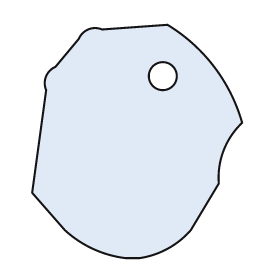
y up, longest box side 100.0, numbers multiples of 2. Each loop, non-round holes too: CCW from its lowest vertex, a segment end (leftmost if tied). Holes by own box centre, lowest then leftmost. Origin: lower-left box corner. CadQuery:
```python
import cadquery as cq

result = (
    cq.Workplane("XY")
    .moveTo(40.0, 0.0)
    .lineTo(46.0, 0.0)
    .threePointArc((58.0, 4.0), (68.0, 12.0))
    .lineTo(80.0, 32.0)
    .threePointArc((82.0, 46.0), (90.0, 58.0))
    .threePointArc((78.0, 82.0), (58.0, 100.0))
    .lineTo(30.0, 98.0)
    .threePointArc((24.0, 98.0), (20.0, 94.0))
    .lineTo(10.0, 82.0)
    .threePointArc((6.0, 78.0), (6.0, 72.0))
    .lineTo(0.0, 28.0)
    .lineTo(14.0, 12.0)
    .threePointArc((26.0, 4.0), (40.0, 0.0))
    .close()
    .moveTo(56.0, 78.0)
    .circle(6.0)
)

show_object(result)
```